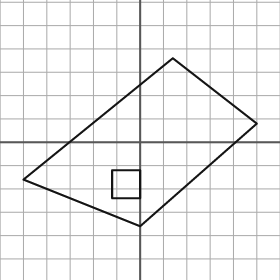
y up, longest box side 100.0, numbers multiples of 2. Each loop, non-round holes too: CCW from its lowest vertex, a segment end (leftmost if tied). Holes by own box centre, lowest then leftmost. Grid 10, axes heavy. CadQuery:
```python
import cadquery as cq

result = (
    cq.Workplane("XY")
    .moveTo(0.0, -36.0)
    .lineTo(50.0, 8.0)
    .lineTo(14.0, 36.0)
    .lineTo(-50.0, -16.0)
    .close()
    .moveTo(-12.0, -24.0)
    .lineTo(0.0, -24.0)
    .lineTo(0.0, -12.0)
    .lineTo(-12.0, -12.0)
    .close()
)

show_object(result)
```